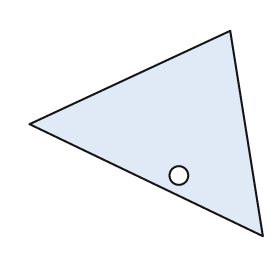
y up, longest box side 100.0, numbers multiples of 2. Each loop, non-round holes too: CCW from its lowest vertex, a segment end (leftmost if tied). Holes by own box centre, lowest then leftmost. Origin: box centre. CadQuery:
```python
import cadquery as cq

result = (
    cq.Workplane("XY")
    .moveTo(50.0, -44.0)
    .lineTo(36.0, 44.0)
    .lineTo(-50.0, 4.0)
    .close()
    .moveTo(14.0, -18.0)
    .circle(4.0)
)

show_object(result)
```